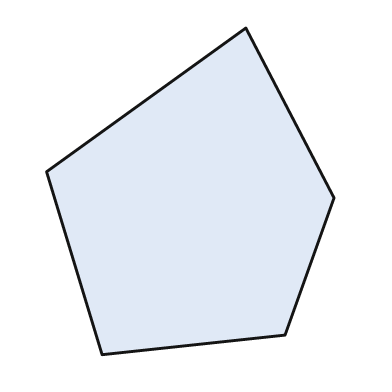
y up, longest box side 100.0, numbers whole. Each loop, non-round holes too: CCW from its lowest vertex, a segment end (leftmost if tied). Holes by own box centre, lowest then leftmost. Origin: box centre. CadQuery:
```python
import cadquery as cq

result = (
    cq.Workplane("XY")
    .moveTo(-27.0, -50.0)
    .lineTo(29.0, -44.0)
    .lineTo(44.0, -2.0)
    .lineTo(17.0, 50.0)
    .lineTo(-44.0, 6.0)
    .close()
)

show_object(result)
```